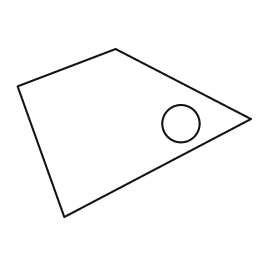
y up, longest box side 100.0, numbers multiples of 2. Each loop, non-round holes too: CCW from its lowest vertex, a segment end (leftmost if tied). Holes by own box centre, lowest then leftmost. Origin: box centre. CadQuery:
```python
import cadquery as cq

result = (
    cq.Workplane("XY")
    .moveTo(-30.0, -36.0)
    .lineTo(50.0, 6.0)
    .lineTo(-8.0, 36.0)
    .lineTo(-50.0, 20.0)
    .close()
    .moveTo(20.0, 4.0)
    .circle(8.0)
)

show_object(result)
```